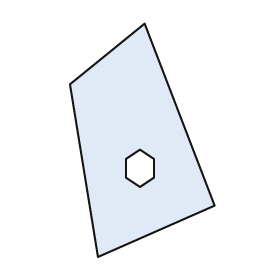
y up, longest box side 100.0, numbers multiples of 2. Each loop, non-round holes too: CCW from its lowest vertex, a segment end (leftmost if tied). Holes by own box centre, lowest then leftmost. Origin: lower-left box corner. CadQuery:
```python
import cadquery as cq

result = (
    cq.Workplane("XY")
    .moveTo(12.0, 0.0)
    .lineTo(62.0, 22.0)
    .lineTo(32.0, 100.0)
    .lineTo(0.0, 74.0)
    .close()
    .moveTo(30.0, 30.0)
    .lineTo(36.0, 34.0)
    .lineTo(36.0, 42.0)
    .lineTo(30.0, 46.0)
    .lineTo(24.0, 42.0)
    .lineTo(24.0, 34.0)
    .close()
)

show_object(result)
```